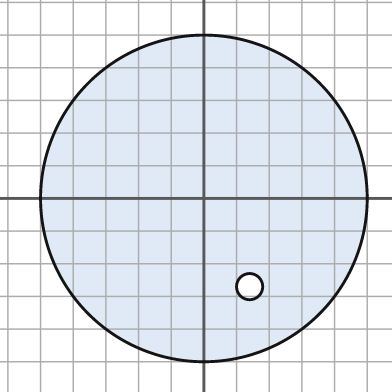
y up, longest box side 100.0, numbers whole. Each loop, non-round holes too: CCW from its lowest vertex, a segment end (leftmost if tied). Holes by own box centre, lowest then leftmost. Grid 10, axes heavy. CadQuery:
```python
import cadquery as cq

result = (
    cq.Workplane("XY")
    .moveTo(0.0, 0.0)
    .circle(50.0)
    .moveTo(14.0, -27.0)
    .circle(4.0)
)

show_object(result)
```